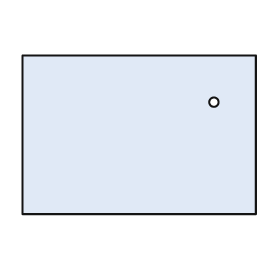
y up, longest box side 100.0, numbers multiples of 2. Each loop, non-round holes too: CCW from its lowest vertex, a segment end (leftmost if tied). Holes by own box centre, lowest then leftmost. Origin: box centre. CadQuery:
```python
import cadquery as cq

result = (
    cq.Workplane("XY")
    .moveTo(-50.0, -34.0)
    .lineTo(50.0, -34.0)
    .lineTo(50.0, 34.0)
    .lineTo(-50.0, 34.0)
    .close()
    .moveTo(32.0, 14.0)
    .circle(2.0)
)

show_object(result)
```